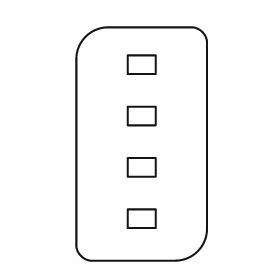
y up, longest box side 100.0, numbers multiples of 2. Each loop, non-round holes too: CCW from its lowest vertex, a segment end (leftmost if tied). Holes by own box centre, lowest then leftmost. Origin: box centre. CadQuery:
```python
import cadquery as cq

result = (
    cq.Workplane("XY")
    .moveTo(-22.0, -50.0)
    .lineTo(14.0, -50.0)
    .threePointArc((24.0, -46.0), (28.0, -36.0))
    .lineTo(28.0, 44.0)
    .threePointArc((26.0, 48.0), (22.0, 50.0))
    .lineTo(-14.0, 50.0)
    .threePointArc((-24.0, 46.0), (-28.0, 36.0))
    .lineTo(-28.0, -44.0)
    .threePointArc((-26.0, -48.0), (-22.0, -50.0))
    .close()
    .moveTo(-6.0, -36.0)
    .lineTo(6.0, -36.0)
    .lineTo(6.0, -28.0)
    .lineTo(-6.0, -28.0)
    .close()
    .moveTo(-6.0, -14.0)
    .lineTo(6.0, -14.0)
    .lineTo(6.0, -6.0)
    .lineTo(-6.0, -6.0)
    .close()
    .moveTo(-6.0, 8.0)
    .lineTo(6.0, 8.0)
    .lineTo(6.0, 16.0)
    .lineTo(-6.0, 16.0)
    .close()
    .moveTo(-6.0, 30.0)
    .lineTo(6.0, 30.0)
    .lineTo(6.0, 38.0)
    .lineTo(-6.0, 38.0)
    .close()
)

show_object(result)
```